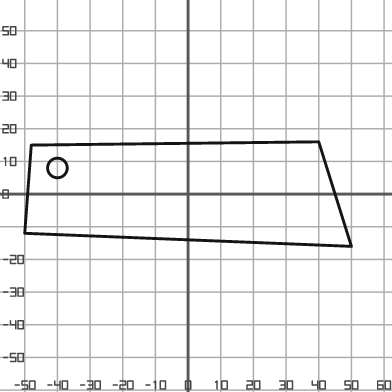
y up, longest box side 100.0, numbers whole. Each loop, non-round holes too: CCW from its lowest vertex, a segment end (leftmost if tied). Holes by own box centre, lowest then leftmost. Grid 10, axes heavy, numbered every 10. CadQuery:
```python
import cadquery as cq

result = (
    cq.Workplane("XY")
    .moveTo(50.0, -16.0)
    .lineTo(40.0, 16.0)
    .lineTo(-48.0, 15.0)
    .lineTo(-50.0, -12.0)
    .close()
    .moveTo(-40.0, 8.0)
    .circle(3.0)
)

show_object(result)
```